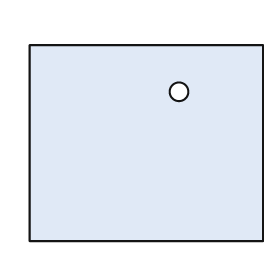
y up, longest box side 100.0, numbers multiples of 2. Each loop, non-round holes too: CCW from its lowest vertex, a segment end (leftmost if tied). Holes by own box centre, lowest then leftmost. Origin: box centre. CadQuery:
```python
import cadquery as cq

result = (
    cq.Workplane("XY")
    .moveTo(-50.0, -42.0)
    .lineTo(50.0, -42.0)
    .lineTo(50.0, 42.0)
    .lineTo(-50.0, 42.0)
    .close()
    .moveTo(14.0, 22.0)
    .circle(4.0)
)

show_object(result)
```